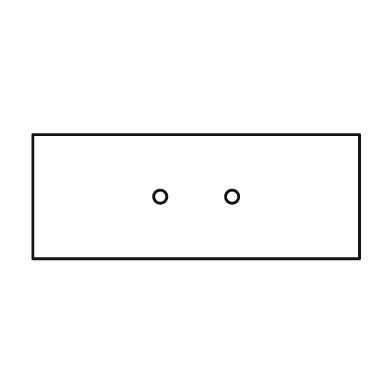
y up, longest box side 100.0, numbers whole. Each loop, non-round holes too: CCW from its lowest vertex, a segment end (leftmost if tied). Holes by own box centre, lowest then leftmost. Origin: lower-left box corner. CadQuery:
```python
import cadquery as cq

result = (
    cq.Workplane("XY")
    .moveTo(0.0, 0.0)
    .lineTo(100.0, 0.0)
    .lineTo(100.0, 38.0)
    .lineTo(0.0, 38.0)
    .close()
    .moveTo(39.0, 19.0)
    .circle(2.0)
    .moveTo(61.0, 19.0)
    .circle(2.0)
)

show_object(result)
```